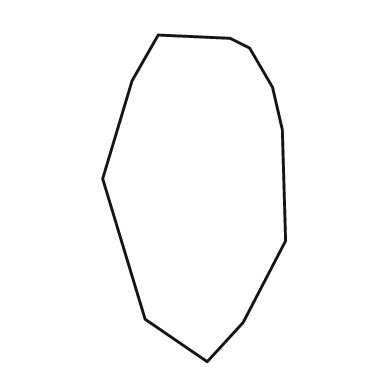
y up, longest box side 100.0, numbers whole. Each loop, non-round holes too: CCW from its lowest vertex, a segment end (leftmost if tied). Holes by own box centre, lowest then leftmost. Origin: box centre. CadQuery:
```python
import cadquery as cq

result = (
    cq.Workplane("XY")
    .moveTo(4.0, -50.0)
    .lineTo(15.0, -38.0)
    .lineTo(28.0, -13.0)
    .lineTo(27.0, 21.0)
    .lineTo(24.0, 34.0)
    .lineTo(17.0, 46.0)
    .lineTo(11.0, 49.0)
    .lineTo(-11.0, 50.0)
    .lineTo(-19.0, 36.0)
    .lineTo(-28.0, 6.0)
    .lineTo(-15.0, -37.0)
    .close()
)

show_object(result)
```